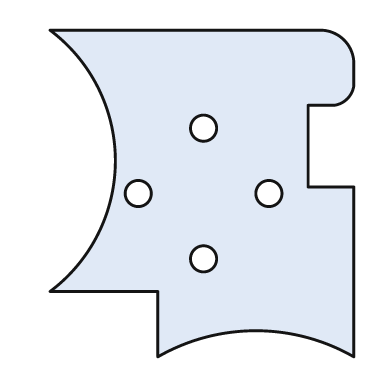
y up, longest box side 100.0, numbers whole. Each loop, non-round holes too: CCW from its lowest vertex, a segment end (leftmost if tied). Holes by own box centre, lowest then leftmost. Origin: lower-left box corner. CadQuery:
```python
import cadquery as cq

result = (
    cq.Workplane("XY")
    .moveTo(33.0, 0.0)
    .threePointArc((63.0, 8.0), (93.0, 0.0))
    .lineTo(93.0, 52.0)
    .lineTo(79.0, 52.0)
    .lineTo(79.0, 77.0)
    .lineTo(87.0, 77.0)
    .threePointArc((91.0, 79.0), (93.0, 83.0))
    .lineTo(93.0, 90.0)
    .threePointArc((90.0, 97.0), (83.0, 100.0))
    .lineTo(0.0, 100.0)
    .threePointArc((20.0, 60.0), (0.0, 20.0))
    .lineTo(33.0, 20.0)
    .close()
    .moveTo(47.0, 30.0)
    .circle(4.0)
    .moveTo(27.0, 50.0)
    .circle(4.0)
    .moveTo(67.0, 50.0)
    .circle(4.0)
    .moveTo(47.0, 70.0)
    .circle(4.0)
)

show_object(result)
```